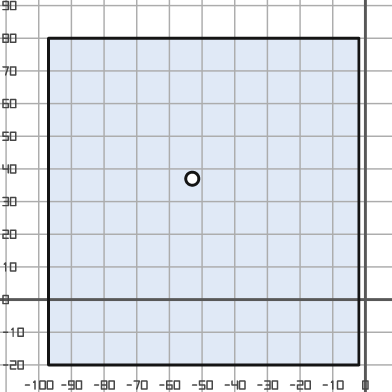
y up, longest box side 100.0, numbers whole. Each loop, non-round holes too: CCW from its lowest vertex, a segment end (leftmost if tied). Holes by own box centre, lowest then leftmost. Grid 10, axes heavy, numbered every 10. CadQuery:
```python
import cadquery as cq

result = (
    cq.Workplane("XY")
    .moveTo(-97.0, -20.0)
    .lineTo(-2.0, -20.0)
    .lineTo(-2.0, 80.0)
    .lineTo(-97.0, 80.0)
    .close()
    .moveTo(-53.0, 37.0)
    .circle(2.0)
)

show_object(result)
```